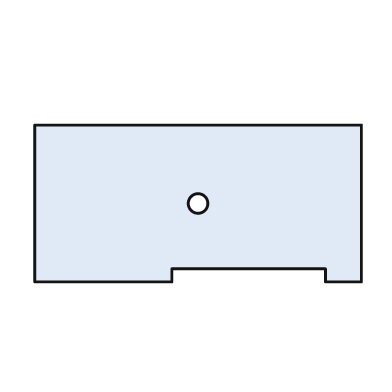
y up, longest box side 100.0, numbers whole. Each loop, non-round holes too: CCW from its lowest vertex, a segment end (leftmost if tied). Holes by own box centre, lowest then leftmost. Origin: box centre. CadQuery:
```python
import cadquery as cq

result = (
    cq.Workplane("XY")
    .moveTo(-50.0, -24.0)
    .lineTo(-8.0, -24.0)
    .lineTo(-8.0, -20.0)
    .lineTo(39.0, -20.0)
    .lineTo(39.0, -24.0)
    .lineTo(50.0, -24.0)
    .lineTo(50.0, 24.0)
    .lineTo(-50.0, 24.0)
    .close()
    .moveTo(0.0, 0.0)
    .circle(3.0)
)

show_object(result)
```